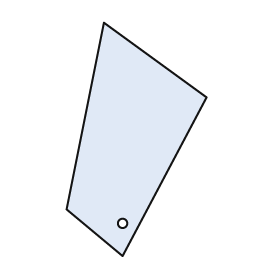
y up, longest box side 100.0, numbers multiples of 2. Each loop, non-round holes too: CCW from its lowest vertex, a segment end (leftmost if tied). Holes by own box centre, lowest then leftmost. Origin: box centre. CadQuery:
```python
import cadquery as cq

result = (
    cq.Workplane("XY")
    .moveTo(-6.0, -50.0)
    .lineTo(30.0, 18.0)
    .lineTo(-14.0, 50.0)
    .lineTo(-30.0, -30.0)
    .close()
    .moveTo(-6.0, -36.0)
    .circle(2.0)
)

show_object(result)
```